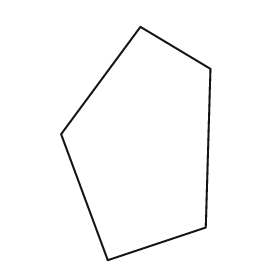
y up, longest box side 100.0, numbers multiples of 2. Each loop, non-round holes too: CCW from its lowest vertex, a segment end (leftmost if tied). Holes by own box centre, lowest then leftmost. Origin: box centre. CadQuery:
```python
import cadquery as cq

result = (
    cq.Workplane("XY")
    .moveTo(-12.0, -50.0)
    .lineTo(30.0, -36.0)
    .lineTo(32.0, 32.0)
    .lineTo(2.0, 50.0)
    .lineTo(-32.0, 4.0)
    .close()
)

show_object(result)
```